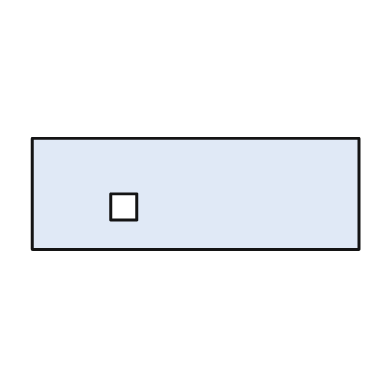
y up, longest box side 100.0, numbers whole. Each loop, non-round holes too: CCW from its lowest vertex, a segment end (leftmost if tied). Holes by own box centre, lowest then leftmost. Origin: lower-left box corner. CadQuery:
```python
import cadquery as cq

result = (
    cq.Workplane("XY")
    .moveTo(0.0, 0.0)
    .lineTo(100.0, 0.0)
    .lineTo(100.0, 34.0)
    .lineTo(0.0, 34.0)
    .close()
    .moveTo(24.0, 9.0)
    .lineTo(32.0, 9.0)
    .lineTo(32.0, 17.0)
    .lineTo(24.0, 17.0)
    .close()
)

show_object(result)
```